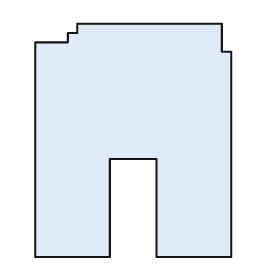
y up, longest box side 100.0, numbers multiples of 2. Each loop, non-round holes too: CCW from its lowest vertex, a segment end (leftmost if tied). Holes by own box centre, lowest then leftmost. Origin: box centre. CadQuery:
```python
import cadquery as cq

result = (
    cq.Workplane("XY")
    .moveTo(-42.0, -50.0)
    .lineTo(-10.0, -50.0)
    .lineTo(-10.0, -8.0)
    .lineTo(10.0, -8.0)
    .lineTo(10.0, -50.0)
    .lineTo(42.0, -50.0)
    .lineTo(42.0, 38.0)
    .lineTo(38.0, 38.0)
    .lineTo(38.0, 50.0)
    .lineTo(-24.0, 50.0)
    .lineTo(-24.0, 46.0)
    .lineTo(-28.0, 46.0)
    .lineTo(-28.0, 42.0)
    .lineTo(-42.0, 42.0)
    .close()
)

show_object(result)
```